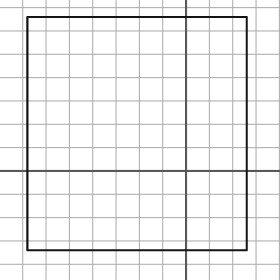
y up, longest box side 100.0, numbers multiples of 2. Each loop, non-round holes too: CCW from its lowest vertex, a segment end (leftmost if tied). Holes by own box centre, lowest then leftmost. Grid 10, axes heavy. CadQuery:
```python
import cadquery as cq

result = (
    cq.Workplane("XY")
    .moveTo(-68.0, -34.0)
    .lineTo(26.0, -34.0)
    .lineTo(26.0, 66.0)
    .lineTo(-68.0, 66.0)
    .close()
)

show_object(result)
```